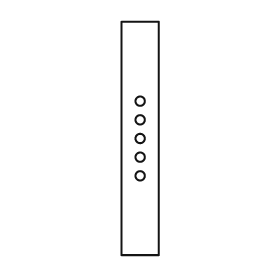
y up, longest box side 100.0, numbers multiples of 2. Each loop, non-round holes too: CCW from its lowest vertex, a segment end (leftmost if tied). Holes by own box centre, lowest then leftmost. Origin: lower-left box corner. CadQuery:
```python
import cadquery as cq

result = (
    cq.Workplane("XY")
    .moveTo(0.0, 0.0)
    .lineTo(16.0, 0.0)
    .lineTo(16.0, 100.0)
    .lineTo(0.0, 100.0)
    .close()
    .moveTo(8.0, 34.0)
    .circle(2.0)
    .moveTo(8.0, 42.0)
    .circle(2.0)
    .moveTo(8.0, 50.0)
    .circle(2.0)
    .moveTo(8.0, 58.0)
    .circle(2.0)
    .moveTo(8.0, 66.0)
    .circle(2.0)
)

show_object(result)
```